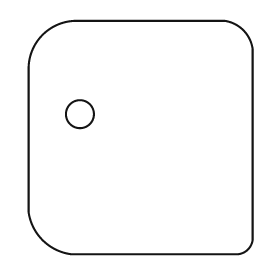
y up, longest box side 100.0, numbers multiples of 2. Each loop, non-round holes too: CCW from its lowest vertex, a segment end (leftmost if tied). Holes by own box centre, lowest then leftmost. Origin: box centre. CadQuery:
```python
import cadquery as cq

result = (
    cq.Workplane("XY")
    .moveTo(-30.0, -50.0)
    .lineTo(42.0, -50.0)
    .threePointArc((46.0, -48.0), (48.0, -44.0))
    .lineTo(48.0, 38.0)
    .threePointArc((44.0, 46.0), (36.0, 50.0))
    .lineTo(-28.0, 50.0)
    .threePointArc((-42.0, 44.0), (-48.0, 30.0))
    .lineTo(-48.0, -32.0)
    .threePointArc((-42.0, -44.0), (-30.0, -50.0))
    .close()
    .moveTo(-26.0, 10.0)
    .circle(6.0)
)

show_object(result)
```